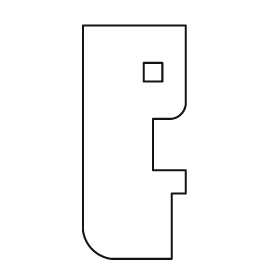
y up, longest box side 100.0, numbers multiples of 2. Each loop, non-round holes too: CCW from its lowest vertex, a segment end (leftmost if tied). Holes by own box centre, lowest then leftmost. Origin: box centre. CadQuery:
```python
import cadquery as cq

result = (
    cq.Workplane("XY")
    .moveTo(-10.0, -50.0)
    .lineTo(16.0, -50.0)
    .lineTo(16.0, -22.0)
    .lineTo(22.0, -22.0)
    .lineTo(22.0, -12.0)
    .lineTo(8.0, -12.0)
    .lineTo(8.0, 10.0)
    .lineTo(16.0, 10.0)
    .threePointArc((20.0, 12.0), (22.0, 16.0))
    .lineTo(22.0, 50.0)
    .lineTo(-22.0, 50.0)
    .lineTo(-22.0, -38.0)
    .threePointArc((-18.0, -46.0), (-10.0, -50.0))
    .close()
    .moveTo(4.0, 26.0)
    .lineTo(12.0, 26.0)
    .lineTo(12.0, 34.0)
    .lineTo(4.0, 34.0)
    .close()
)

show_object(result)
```